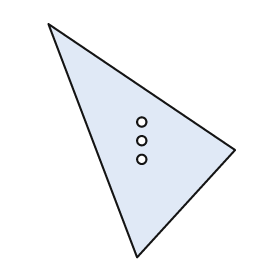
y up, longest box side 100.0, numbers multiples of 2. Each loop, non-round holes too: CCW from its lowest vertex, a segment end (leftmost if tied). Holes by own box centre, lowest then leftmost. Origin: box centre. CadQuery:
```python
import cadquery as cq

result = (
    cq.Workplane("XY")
    .moveTo(-2.0, -50.0)
    .lineTo(40.0, -4.0)
    .lineTo(-40.0, 50.0)
    .close()
    .moveTo(0.0, -8.0)
    .circle(2.0)
    .moveTo(0.0, 0.0)
    .circle(2.0)
    .moveTo(0.0, 8.0)
    .circle(2.0)
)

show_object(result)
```